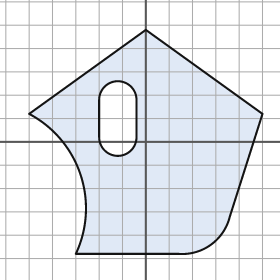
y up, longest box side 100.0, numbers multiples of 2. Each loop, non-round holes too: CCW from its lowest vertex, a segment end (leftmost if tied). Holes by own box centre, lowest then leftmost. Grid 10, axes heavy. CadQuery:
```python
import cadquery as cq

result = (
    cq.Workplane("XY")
    .moveTo(-30.0, -48.0)
    .lineTo(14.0, -48.0)
    .threePointArc((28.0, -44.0), (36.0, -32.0))
    .lineTo(50.0, 12.0)
    .lineTo(0.0, 48.0)
    .lineTo(-50.0, 12.0)
    .threePointArc((-28.0, -14.0), (-30.0, -48.0))
    .close()
    .moveTo(-20.0, 2.0)
    .threePointArc((-12.0, -6.0), (-4.0, 2.0))
    .lineTo(-4.0, 18.0)
    .threePointArc((-12.0, 26.0), (-20.0, 18.0))
    .close()
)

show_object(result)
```